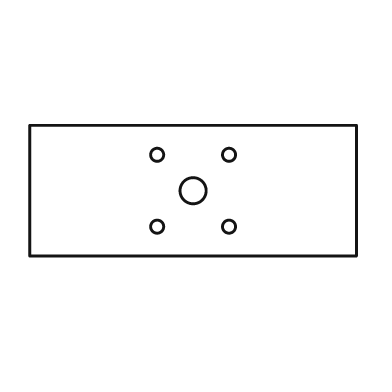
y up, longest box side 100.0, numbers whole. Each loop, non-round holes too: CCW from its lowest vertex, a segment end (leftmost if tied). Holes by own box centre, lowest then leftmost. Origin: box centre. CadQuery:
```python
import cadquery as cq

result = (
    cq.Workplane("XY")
    .moveTo(-50.0, -20.0)
    .lineTo(50.0, -20.0)
    .lineTo(50.0, 20.0)
    .lineTo(-50.0, 20.0)
    .close()
    .moveTo(-11.0, -11.0)
    .circle(2.0)
    .moveTo(11.0, -11.0)
    .circle(2.0)
    .moveTo(0.0, 0.0)
    .circle(4.0)
    .moveTo(-11.0, 11.0)
    .circle(2.0)
    .moveTo(11.0, 11.0)
    .circle(2.0)
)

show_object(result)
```